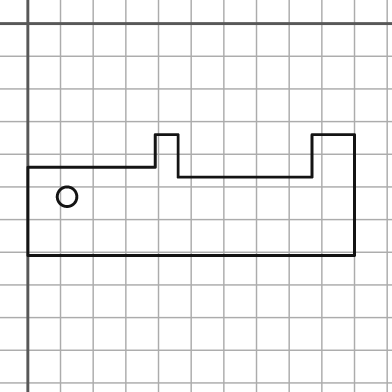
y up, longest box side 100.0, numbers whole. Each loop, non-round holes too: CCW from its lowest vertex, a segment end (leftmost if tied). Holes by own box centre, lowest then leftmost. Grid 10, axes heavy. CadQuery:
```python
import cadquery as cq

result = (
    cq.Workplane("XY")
    .moveTo(0.0, -71.0)
    .lineTo(100.0, -71.0)
    .lineTo(100.0, -34.0)
    .lineTo(87.0, -34.0)
    .lineTo(87.0, -47.0)
    .lineTo(46.0, -47.0)
    .lineTo(46.0, -34.0)
    .lineTo(39.0, -34.0)
    .lineTo(39.0, -44.0)
    .lineTo(0.0, -44.0)
    .close()
    .moveTo(12.0, -53.0)
    .circle(3.0)
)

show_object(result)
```